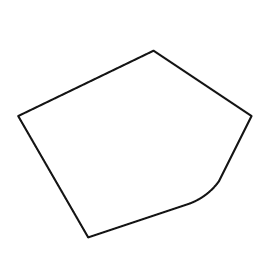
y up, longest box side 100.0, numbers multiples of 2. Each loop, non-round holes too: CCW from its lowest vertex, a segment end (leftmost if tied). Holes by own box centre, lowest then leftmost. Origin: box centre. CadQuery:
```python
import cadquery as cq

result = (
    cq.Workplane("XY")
    .moveTo(-20.0, -40.0)
    .lineTo(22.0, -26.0)
    .threePointArc((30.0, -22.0), (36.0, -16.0))
    .lineTo(50.0, 12.0)
    .lineTo(8.0, 40.0)
    .lineTo(-50.0, 12.0)
    .close()
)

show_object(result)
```